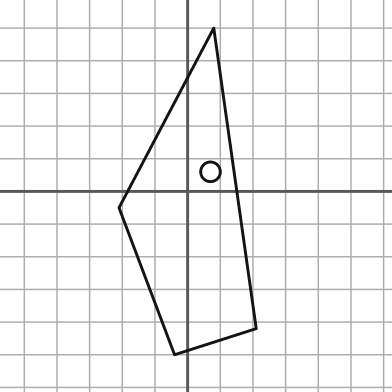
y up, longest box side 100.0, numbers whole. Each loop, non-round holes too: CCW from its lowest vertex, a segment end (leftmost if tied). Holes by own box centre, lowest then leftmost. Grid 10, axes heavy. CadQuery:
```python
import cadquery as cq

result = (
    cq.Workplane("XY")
    .moveTo(-4.0, -50.0)
    .lineTo(21.0, -42.0)
    .lineTo(8.0, 50.0)
    .lineTo(-21.0, -5.0)
    .close()
    .moveTo(7.0, 6.0)
    .circle(3.0)
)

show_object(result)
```